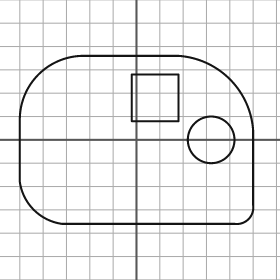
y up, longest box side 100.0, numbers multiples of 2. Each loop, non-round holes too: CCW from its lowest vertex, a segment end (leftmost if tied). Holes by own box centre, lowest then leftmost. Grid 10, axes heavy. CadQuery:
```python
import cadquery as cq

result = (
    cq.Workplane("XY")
    .moveTo(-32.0, -36.0)
    .lineTo(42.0, -36.0)
    .threePointArc((48.0, -34.0), (50.0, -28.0))
    .lineTo(50.0, 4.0)
    .threePointArc((40.0, 26.0), (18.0, 36.0))
    .lineTo(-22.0, 36.0)
    .threePointArc((-42.0, 28.0), (-50.0, 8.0))
    .lineTo(-50.0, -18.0)
    .threePointArc((-44.0, -30.0), (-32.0, -36.0))
    .close()
    .moveTo(32.0, 0.0)
    .circle(10.0)
    .moveTo(-2.0, 8.0)
    .lineTo(18.0, 8.0)
    .lineTo(18.0, 28.0)
    .lineTo(-2.0, 28.0)
    .close()
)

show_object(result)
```